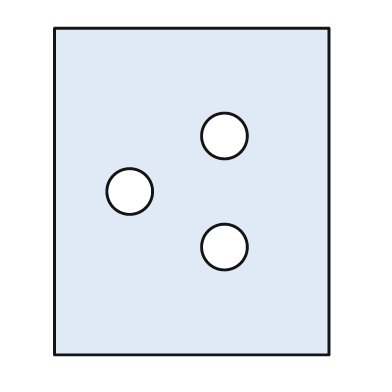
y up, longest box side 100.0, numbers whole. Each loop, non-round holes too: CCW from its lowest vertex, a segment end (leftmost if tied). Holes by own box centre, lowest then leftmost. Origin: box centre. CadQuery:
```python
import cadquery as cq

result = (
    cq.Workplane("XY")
    .moveTo(-42.0, -50.0)
    .lineTo(42.0, -50.0)
    .lineTo(42.0, 50.0)
    .lineTo(-42.0, 50.0)
    .close()
    .moveTo(10.0, -17.0)
    .circle(7.0)
    .moveTo(-19.0, 0.0)
    .circle(7.0)
    .moveTo(10.0, 17.0)
    .circle(7.0)
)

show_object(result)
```